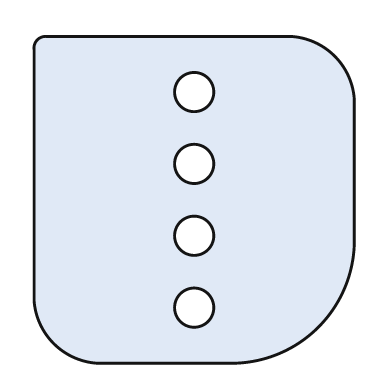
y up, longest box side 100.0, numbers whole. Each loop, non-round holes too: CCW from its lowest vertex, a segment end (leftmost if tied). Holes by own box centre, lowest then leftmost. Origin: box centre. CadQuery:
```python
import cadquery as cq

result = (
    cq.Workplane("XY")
    .moveTo(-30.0, -50.0)
    .lineTo(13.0, -50.0)
    .threePointArc((38.0, -39.0), (49.0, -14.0))
    .lineTo(49.0, 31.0)
    .threePointArc((43.0, 44.0), (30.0, 50.0))
    .lineTo(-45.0, 50.0)
    .threePointArc((-48.0, 49.0), (-49.0, 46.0))
    .lineTo(-49.0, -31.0)
    .threePointArc((-43.0, -44.0), (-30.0, -50.0))
    .close()
    .moveTo(0.0, -33.0)
    .circle(6.0)
    .moveTo(0.0, -11.0)
    .circle(6.0)
    .moveTo(0.0, 11.0)
    .circle(6.0)
    .moveTo(0.0, 33.0)
    .circle(6.0)
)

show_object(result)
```